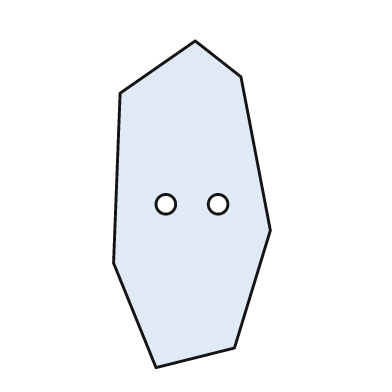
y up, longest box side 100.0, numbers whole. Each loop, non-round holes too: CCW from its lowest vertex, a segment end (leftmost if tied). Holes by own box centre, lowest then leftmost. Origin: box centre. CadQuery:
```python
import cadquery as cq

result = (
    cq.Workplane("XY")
    .moveTo(-11.0, -50.0)
    .lineTo(13.0, -44.0)
    .lineTo(24.0, -8.0)
    .lineTo(15.0, 39.0)
    .lineTo(1.0, 50.0)
    .lineTo(-22.0, 34.0)
    .lineTo(-24.0, -18.0)
    .close()
    .moveTo(-8.0, 0.0)
    .circle(3.0)
    .moveTo(8.0, 0.0)
    .circle(3.0)
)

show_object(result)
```